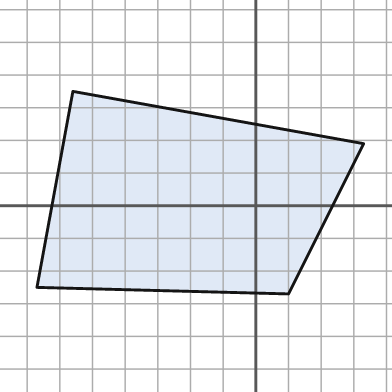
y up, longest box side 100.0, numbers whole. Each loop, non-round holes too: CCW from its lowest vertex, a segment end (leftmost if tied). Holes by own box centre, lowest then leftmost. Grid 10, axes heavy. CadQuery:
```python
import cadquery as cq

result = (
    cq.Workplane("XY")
    .moveTo(10.0, -27.0)
    .lineTo(33.0, 19.0)
    .lineTo(-56.0, 35.0)
    .lineTo(-67.0, -25.0)
    .close()
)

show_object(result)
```